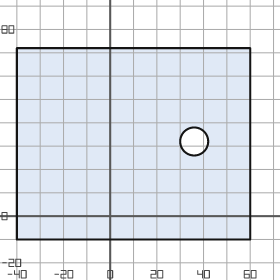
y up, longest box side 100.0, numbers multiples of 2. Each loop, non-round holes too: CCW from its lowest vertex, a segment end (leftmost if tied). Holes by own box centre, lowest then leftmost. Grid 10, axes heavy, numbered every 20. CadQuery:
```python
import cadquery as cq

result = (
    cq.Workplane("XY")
    .moveTo(-40.0, -10.0)
    .lineTo(60.0, -10.0)
    .lineTo(60.0, 72.0)
    .lineTo(-40.0, 72.0)
    .close()
    .moveTo(36.0, 32.0)
    .circle(6.0)
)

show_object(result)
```